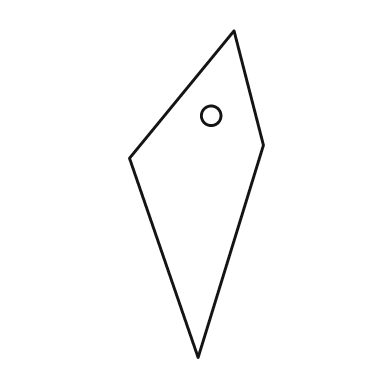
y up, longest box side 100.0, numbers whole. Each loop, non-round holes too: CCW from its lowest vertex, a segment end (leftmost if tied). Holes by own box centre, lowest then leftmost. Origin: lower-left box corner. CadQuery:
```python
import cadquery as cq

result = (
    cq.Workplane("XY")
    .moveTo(21.0, 0.0)
    .lineTo(41.0, 65.0)
    .lineTo(32.0, 100.0)
    .lineTo(0.0, 61.0)
    .close()
    .moveTo(25.0, 74.0)
    .circle(3.0)
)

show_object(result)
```